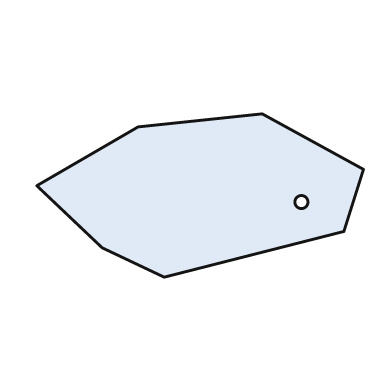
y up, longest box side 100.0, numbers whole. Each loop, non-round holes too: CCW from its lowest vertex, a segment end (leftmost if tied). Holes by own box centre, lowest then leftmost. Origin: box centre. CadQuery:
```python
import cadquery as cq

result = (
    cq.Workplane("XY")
    .moveTo(-11.0, -25.0)
    .lineTo(44.0, -11.0)
    .lineTo(50.0, 8.0)
    .lineTo(19.0, 25.0)
    .lineTo(-19.0, 21.0)
    .lineTo(-50.0, 3.0)
    .lineTo(-30.0, -16.0)
    .close()
    .moveTo(31.0, -2.0)
    .circle(2.0)
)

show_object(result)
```